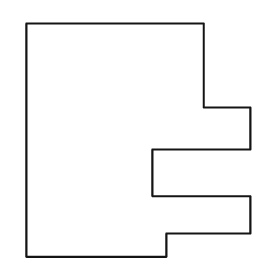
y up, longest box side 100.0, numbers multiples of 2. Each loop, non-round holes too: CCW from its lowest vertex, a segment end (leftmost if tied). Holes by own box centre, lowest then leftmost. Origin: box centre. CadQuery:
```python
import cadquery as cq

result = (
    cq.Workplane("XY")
    .moveTo(-48.0, -50.0)
    .lineTo(12.0, -50.0)
    .lineTo(12.0, -40.0)
    .lineTo(48.0, -40.0)
    .lineTo(48.0, -24.0)
    .lineTo(6.0, -24.0)
    .lineTo(6.0, -4.0)
    .lineTo(48.0, -4.0)
    .lineTo(48.0, 14.0)
    .lineTo(28.0, 14.0)
    .lineTo(28.0, 50.0)
    .lineTo(-48.0, 50.0)
    .close()
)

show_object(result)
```